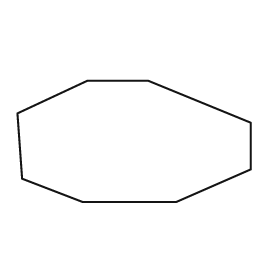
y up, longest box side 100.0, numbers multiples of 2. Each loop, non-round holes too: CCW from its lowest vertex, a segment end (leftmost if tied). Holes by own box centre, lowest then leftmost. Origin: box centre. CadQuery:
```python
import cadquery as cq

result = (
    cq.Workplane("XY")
    .moveTo(-22.0, -26.0)
    .lineTo(18.0, -26.0)
    .lineTo(50.0, -12.0)
    .lineTo(50.0, 8.0)
    .lineTo(6.0, 26.0)
    .lineTo(-20.0, 26.0)
    .lineTo(-50.0, 12.0)
    .lineTo(-48.0, -16.0)
    .close()
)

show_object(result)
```